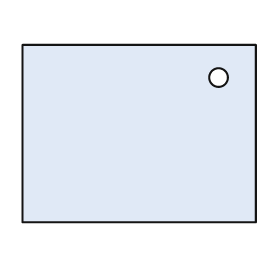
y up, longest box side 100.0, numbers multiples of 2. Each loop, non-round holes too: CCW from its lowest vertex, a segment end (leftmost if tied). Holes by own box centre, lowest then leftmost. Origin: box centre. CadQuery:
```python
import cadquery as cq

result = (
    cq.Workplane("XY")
    .moveTo(-50.0, -38.0)
    .lineTo(50.0, -38.0)
    .lineTo(50.0, 38.0)
    .lineTo(-50.0, 38.0)
    .close()
    .moveTo(34.0, 24.0)
    .circle(4.0)
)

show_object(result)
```